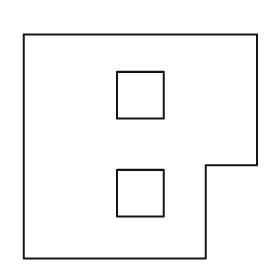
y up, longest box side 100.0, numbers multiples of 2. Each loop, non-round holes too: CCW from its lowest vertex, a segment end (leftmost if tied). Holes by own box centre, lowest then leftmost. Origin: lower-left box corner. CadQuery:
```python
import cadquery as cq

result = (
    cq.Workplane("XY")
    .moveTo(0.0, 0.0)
    .lineTo(78.0, 0.0)
    .lineTo(78.0, 40.0)
    .lineTo(100.0, 40.0)
    .lineTo(100.0, 96.0)
    .lineTo(0.0, 96.0)
    .close()
    .moveTo(40.0, 18.0)
    .lineTo(60.0, 18.0)
    .lineTo(60.0, 38.0)
    .lineTo(40.0, 38.0)
    .close()
    .moveTo(40.0, 60.0)
    .lineTo(60.0, 60.0)
    .lineTo(60.0, 80.0)
    .lineTo(40.0, 80.0)
    .close()
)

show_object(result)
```